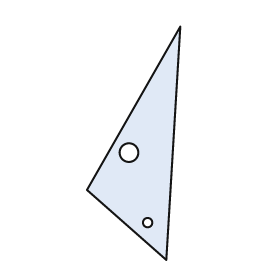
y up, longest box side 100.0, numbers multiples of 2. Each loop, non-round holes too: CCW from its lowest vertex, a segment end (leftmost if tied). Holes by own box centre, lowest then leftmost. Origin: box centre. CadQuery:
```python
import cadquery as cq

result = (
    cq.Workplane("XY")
    .moveTo(14.0, -50.0)
    .lineTo(20.0, 50.0)
    .lineTo(-20.0, -20.0)
    .close()
    .moveTo(6.0, -34.0)
    .circle(2.0)
    .moveTo(-2.0, -4.0)
    .circle(4.0)
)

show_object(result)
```